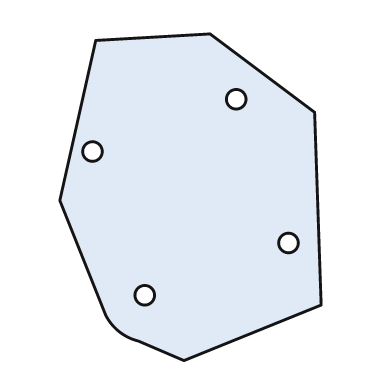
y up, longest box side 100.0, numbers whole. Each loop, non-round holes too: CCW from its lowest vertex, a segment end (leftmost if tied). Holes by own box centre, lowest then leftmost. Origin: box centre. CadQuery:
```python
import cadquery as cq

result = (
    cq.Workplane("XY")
    .moveTo(-2.0, -50.0)
    .lineTo(40.0, -33.0)
    .lineTo(38.0, 26.0)
    .lineTo(6.0, 50.0)
    .lineTo(-29.0, 48.0)
    .lineTo(-40.0, -1.0)
    .lineTo(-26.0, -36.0)
    .threePointArc((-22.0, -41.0), (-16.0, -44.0))
    .close()
    .moveTo(-14.0, -30.0)
    .circle(3.0)
    .moveTo(30.0, -14.0)
    .circle(3.0)
    .moveTo(-30.0, 14.0)
    .circle(3.0)
    .moveTo(14.0, 30.0)
    .circle(3.0)
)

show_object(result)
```